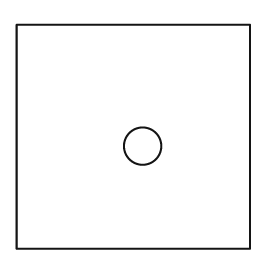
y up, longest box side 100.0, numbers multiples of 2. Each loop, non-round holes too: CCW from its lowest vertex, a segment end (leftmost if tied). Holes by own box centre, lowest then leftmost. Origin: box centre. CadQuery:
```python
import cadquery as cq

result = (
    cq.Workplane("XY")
    .moveTo(-50.0, -48.0)
    .lineTo(50.0, -48.0)
    .lineTo(50.0, 48.0)
    .lineTo(-50.0, 48.0)
    .close()
    .moveTo(4.0, -4.0)
    .circle(8.0)
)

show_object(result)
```